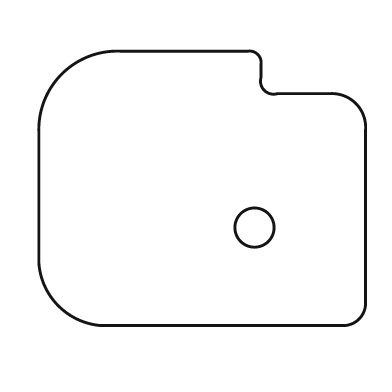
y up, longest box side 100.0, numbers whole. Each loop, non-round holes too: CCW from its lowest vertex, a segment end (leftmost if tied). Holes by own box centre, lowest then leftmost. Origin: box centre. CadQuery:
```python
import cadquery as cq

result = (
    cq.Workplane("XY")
    .moveTo(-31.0, -42.0)
    .lineTo(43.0, -42.0)
    .threePointArc((48.0, -40.0), (50.0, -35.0))
    .lineTo(50.0, 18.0)
    .threePointArc((47.0, 26.0), (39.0, 29.0))
    .lineTo(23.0, 29.0)
    .threePointArc((19.0, 30.0), (18.0, 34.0))
    .lineTo(18.0, 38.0)
    .threePointArc((17.0, 41.0), (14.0, 42.0))
    .lineTo(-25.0, 42.0)
    .threePointArc((-43.0, 35.0), (-50.0, 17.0))
    .lineTo(-50.0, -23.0)
    .threePointArc((-44.0, -36.0), (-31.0, -42.0))
    .close()
    .moveTo(16.0, -12.0)
    .circle(6.0)
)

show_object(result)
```